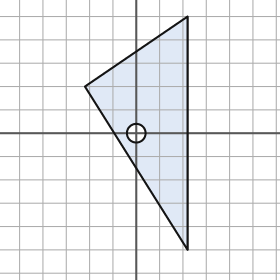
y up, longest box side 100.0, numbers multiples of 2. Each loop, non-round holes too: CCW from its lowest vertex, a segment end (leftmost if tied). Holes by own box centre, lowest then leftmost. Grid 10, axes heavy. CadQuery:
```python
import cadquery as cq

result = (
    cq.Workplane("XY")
    .moveTo(22.0, -50.0)
    .lineTo(22.0, 50.0)
    .lineTo(-22.0, 20.0)
    .close()
    .moveTo(0.0, 0.0)
    .circle(4.0)
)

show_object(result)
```